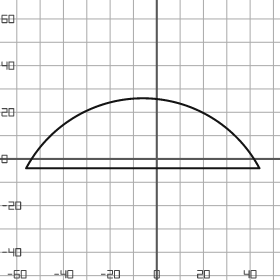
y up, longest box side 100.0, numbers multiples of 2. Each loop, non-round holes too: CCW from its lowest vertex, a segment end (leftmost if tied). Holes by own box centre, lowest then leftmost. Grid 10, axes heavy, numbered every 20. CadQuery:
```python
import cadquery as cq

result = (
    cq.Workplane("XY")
    .moveTo(-56.0, -4.0)
    .lineTo(44.0, -4.0)
    .threePointArc((-6.0, 26.0), (-56.0, -4.0))
    .close()
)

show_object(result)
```